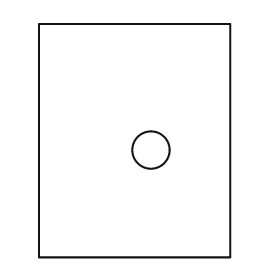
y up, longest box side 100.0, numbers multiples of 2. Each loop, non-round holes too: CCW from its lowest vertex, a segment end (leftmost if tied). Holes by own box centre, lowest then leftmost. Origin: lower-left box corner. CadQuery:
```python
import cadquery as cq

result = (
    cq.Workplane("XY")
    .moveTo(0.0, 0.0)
    .lineTo(82.0, 0.0)
    .lineTo(82.0, 100.0)
    .lineTo(0.0, 100.0)
    .close()
    .moveTo(48.0, 46.0)
    .circle(8.0)
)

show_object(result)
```